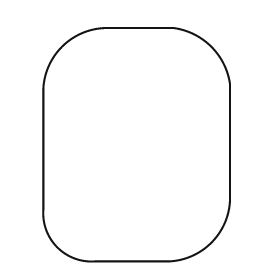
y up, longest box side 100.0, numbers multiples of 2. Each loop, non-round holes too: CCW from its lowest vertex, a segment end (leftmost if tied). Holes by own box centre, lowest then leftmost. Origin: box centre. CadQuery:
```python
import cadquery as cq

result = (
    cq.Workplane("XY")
    .moveTo(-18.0, -50.0)
    .lineTo(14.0, -50.0)
    .threePointArc((32.0, -42.0), (40.0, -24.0))
    .lineTo(40.0, 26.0)
    .threePointArc((32.0, 42.0), (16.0, 50.0))
    .lineTo(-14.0, 50.0)
    .threePointArc((-32.0, 42.0), (-40.0, 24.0))
    .lineTo(-40.0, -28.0)
    .threePointArc((-34.0, -44.0), (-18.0, -50.0))
    .close()
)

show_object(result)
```